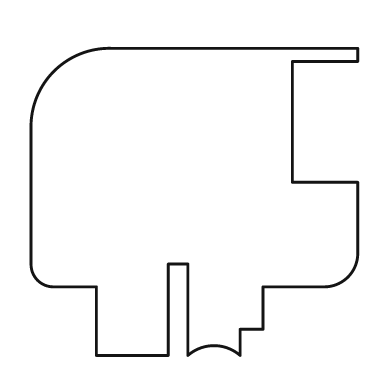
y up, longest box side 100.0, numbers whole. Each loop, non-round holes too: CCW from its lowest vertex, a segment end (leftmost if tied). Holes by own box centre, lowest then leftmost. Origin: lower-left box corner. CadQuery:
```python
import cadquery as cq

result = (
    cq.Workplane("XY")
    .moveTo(20.0, 0.0)
    .lineTo(42.0, 0.0)
    .lineTo(42.0, 28.0)
    .lineTo(48.0, 28.0)
    .lineTo(48.0, 0.0)
    .threePointArc((56.0, 3.0), (64.0, 0.0))
    .lineTo(64.0, 8.0)
    .lineTo(71.0, 8.0)
    .lineTo(71.0, 21.0)
    .lineTo(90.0, 21.0)
    .threePointArc((97.0, 24.0), (100.0, 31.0))
    .lineTo(100.0, 53.0)
    .lineTo(80.0, 53.0)
    .lineTo(80.0, 90.0)
    .lineTo(100.0, 90.0)
    .lineTo(100.0, 94.0)
    .lineTo(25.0, 94.0)
    .threePointArc((7.0, 87.0), (0.0, 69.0))
    .lineTo(0.0, 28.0)
    .threePointArc((2.0, 23.0), (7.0, 21.0))
    .lineTo(20.0, 21.0)
    .close()
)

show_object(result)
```